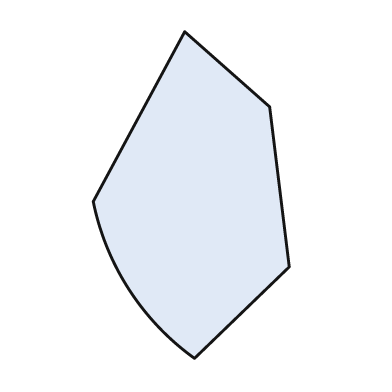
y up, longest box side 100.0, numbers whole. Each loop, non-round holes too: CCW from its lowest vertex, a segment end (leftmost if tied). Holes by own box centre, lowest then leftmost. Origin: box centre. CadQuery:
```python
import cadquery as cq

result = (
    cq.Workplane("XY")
    .moveTo(1.0, -50.0)
    .lineTo(30.0, -22.0)
    .lineTo(24.0, 27.0)
    .lineTo(-2.0, 50.0)
    .lineTo(-30.0, -2.0)
    .threePointArc((-19.0, -29.0), (1.0, -50.0))
    .close()
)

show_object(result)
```